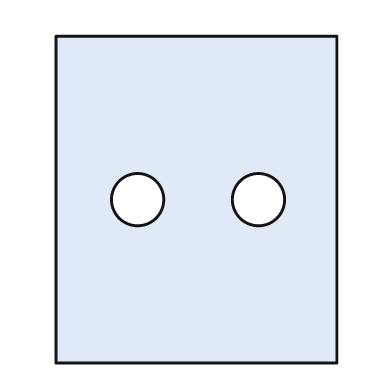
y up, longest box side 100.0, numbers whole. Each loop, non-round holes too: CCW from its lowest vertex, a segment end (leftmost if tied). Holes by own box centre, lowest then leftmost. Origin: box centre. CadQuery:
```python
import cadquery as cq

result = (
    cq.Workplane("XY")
    .moveTo(-43.0, -50.0)
    .lineTo(43.0, -50.0)
    .lineTo(43.0, 50.0)
    .lineTo(-43.0, 50.0)
    .close()
    .moveTo(-18.0, 0.0)
    .circle(8.0)
    .moveTo(19.0, 0.0)
    .circle(8.0)
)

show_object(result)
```